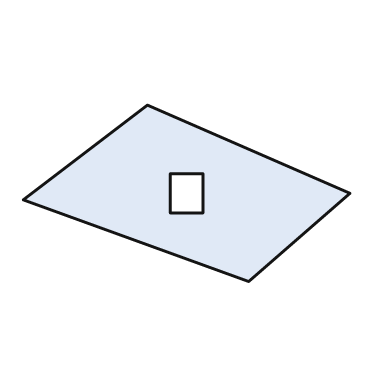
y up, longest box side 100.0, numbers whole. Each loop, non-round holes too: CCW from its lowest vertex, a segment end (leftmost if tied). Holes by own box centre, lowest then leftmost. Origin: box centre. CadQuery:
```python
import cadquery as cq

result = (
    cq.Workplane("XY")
    .moveTo(19.0, -27.0)
    .lineTo(50.0, 0.0)
    .lineTo(-12.0, 27.0)
    .lineTo(-50.0, -2.0)
    .close()
    .moveTo(-5.0, -6.0)
    .lineTo(5.0, -6.0)
    .lineTo(5.0, 6.0)
    .lineTo(-5.0, 6.0)
    .close()
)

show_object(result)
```